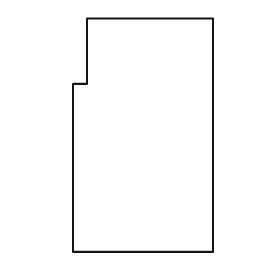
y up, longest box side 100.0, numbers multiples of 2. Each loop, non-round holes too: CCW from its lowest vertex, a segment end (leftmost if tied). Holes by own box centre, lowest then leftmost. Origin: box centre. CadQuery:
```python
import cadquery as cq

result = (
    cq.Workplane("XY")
    .moveTo(-30.0, -50.0)
    .lineTo(30.0, -50.0)
    .lineTo(30.0, 50.0)
    .lineTo(-24.0, 50.0)
    .lineTo(-24.0, 22.0)
    .lineTo(-30.0, 22.0)
    .close()
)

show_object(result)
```